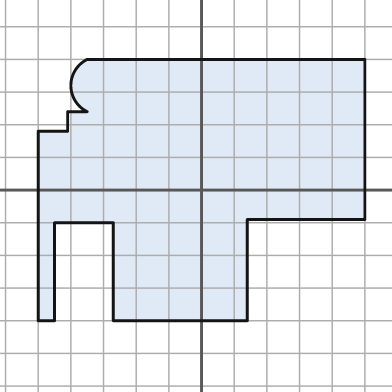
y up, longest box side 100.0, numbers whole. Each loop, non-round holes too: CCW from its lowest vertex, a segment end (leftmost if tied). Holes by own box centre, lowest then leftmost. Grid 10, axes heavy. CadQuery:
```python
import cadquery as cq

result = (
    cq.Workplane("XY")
    .moveTo(-50.0, -40.0)
    .lineTo(-45.0, -40.0)
    .lineTo(-45.0, -10.0)
    .lineTo(-27.0, -10.0)
    .lineTo(-27.0, -40.0)
    .lineTo(14.0, -40.0)
    .lineTo(14.0, -9.0)
    .lineTo(50.0, -9.0)
    .lineTo(50.0, 40.0)
    .lineTo(-35.0, 40.0)
    .threePointArc((-40.0, 32.0), (-35.0, 24.0))
    .lineTo(-41.0, 24.0)
    .lineTo(-41.0, 18.0)
    .lineTo(-50.0, 18.0)
    .close()
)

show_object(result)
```